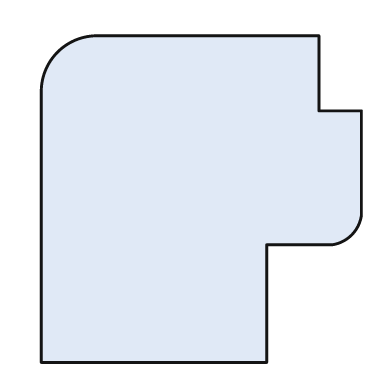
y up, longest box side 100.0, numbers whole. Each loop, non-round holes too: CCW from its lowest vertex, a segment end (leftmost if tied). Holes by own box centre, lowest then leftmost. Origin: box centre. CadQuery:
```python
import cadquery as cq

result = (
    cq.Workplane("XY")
    .moveTo(-49.0, -50.0)
    .lineTo(20.0, -50.0)
    .lineTo(20.0, -14.0)
    .lineTo(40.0, -14.0)
    .threePointArc((46.0, -11.0), (49.0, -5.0))
    .lineTo(49.0, 27.0)
    .lineTo(36.0, 27.0)
    .lineTo(36.0, 50.0)
    .lineTo(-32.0, 50.0)
    .threePointArc((-44.0, 45.0), (-49.0, 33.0))
    .close()
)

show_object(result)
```